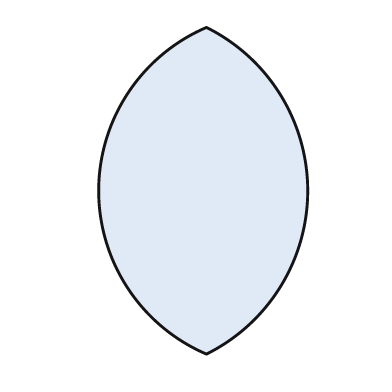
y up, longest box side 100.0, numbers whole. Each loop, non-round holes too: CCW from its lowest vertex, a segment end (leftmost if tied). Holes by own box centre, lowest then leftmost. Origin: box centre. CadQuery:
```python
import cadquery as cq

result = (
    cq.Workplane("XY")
    .moveTo(1.0, -50.0)
    .threePointArc((32.0, 0.0), (1.0, 50.0))
    .threePointArc((-32.0, 0.0), (1.0, -50.0))
    .close()
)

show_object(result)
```